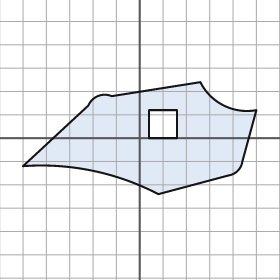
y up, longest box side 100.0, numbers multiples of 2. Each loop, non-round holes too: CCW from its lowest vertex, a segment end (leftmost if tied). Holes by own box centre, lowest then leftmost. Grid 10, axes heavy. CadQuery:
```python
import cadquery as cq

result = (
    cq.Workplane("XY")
    .moveTo(8.0, -24.0)
    .lineTo(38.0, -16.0)
    .threePointArc((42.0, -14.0), (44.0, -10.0))
    .lineTo(50.0, 12.0)
    .threePointArc((36.0, 14.0), (26.0, 24.0))
    .lineTo(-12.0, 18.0)
    .threePointArc((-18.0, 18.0), (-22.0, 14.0))
    .lineTo(-50.0, -12.0)
    .threePointArc((-20.0, -14.0), (8.0, -24.0))
    .close()
    .moveTo(4.0, 0.0)
    .lineTo(16.0, 0.0)
    .lineTo(16.0, 12.0)
    .lineTo(4.0, 12.0)
    .close()
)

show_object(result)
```